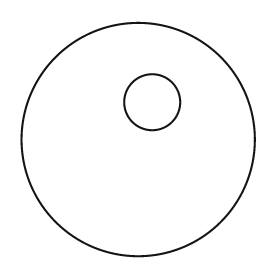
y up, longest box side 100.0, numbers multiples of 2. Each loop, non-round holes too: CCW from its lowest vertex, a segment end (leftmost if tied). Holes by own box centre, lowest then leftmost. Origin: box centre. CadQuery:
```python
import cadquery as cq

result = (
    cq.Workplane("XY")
    .moveTo(0.0, 0.0)
    .circle(50.0)
    .moveTo(6.0, 16.0)
    .circle(12.0)
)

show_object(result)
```